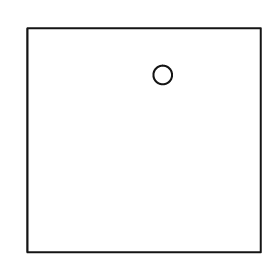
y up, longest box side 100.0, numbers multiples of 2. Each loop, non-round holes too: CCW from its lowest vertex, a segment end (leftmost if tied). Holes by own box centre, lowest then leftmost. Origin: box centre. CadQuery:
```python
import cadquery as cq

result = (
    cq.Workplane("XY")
    .moveTo(-50.0, -48.0)
    .lineTo(50.0, -48.0)
    .lineTo(50.0, 48.0)
    .lineTo(-50.0, 48.0)
    .close()
    .moveTo(8.0, 28.0)
    .circle(4.0)
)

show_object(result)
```